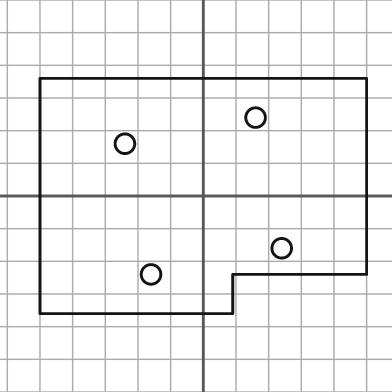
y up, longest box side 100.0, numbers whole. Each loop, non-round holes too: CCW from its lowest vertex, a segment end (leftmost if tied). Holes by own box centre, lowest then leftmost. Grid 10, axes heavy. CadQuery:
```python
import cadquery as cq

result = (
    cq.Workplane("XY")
    .moveTo(-50.0, -36.0)
    .lineTo(9.0, -36.0)
    .lineTo(9.0, -24.0)
    .lineTo(50.0, -24.0)
    .lineTo(50.0, 36.0)
    .lineTo(-50.0, 36.0)
    .close()
    .moveTo(-16.0, -24.0)
    .circle(3.0)
    .moveTo(24.0, -16.0)
    .circle(3.0)
    .moveTo(-24.0, 16.0)
    .circle(3.0)
    .moveTo(16.0, 24.0)
    .circle(3.0)
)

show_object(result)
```